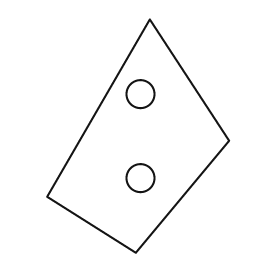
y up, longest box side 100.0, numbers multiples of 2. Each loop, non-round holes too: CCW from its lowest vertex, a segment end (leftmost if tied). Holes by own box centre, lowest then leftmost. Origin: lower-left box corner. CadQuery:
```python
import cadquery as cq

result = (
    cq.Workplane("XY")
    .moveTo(38.0, 0.0)
    .lineTo(78.0, 48.0)
    .lineTo(44.0, 100.0)
    .lineTo(0.0, 24.0)
    .close()
    .moveTo(40.0, 32.0)
    .circle(6.0)
    .moveTo(40.0, 68.0)
    .circle(6.0)
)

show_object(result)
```